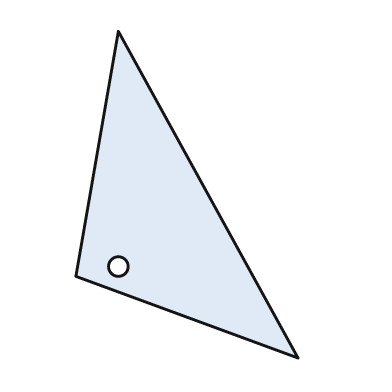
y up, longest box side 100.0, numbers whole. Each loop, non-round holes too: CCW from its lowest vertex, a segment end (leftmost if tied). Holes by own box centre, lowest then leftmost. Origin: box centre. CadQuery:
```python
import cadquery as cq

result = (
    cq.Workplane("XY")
    .moveTo(34.0, -50.0)
    .lineTo(-21.0, 50.0)
    .lineTo(-34.0, -25.0)
    .close()
    .moveTo(-21.0, -22.0)
    .circle(3.0)
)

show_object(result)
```